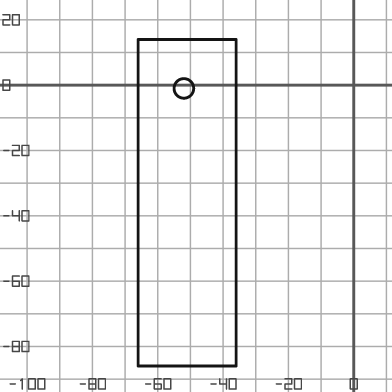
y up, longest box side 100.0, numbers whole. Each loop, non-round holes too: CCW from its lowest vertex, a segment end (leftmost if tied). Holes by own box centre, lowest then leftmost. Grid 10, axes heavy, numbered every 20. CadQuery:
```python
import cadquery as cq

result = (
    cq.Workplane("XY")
    .moveTo(-66.0, -86.0)
    .lineTo(-36.0, -86.0)
    .lineTo(-36.0, 14.0)
    .lineTo(-66.0, 14.0)
    .close()
    .moveTo(-52.0, -1.0)
    .circle(3.0)
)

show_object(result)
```